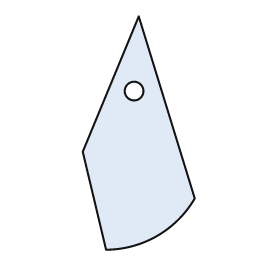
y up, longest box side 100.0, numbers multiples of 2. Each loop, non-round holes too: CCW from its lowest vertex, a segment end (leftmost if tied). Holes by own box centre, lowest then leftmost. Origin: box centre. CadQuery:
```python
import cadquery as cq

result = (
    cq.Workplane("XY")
    .moveTo(-14.0, -50.0)
    .threePointArc((8.0, -44.0), (24.0, -28.0))
    .lineTo(0.0, 50.0)
    .lineTo(-24.0, -8.0)
    .close()
    .moveTo(-2.0, 18.0)
    .circle(4.0)
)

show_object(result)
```